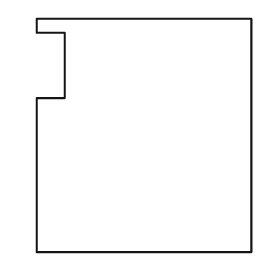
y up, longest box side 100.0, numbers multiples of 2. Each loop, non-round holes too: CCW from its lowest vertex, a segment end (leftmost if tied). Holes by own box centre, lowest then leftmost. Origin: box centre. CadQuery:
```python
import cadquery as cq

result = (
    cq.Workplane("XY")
    .moveTo(-46.0, -50.0)
    .lineTo(46.0, -50.0)
    .lineTo(46.0, 50.0)
    .lineTo(-46.0, 50.0)
    .lineTo(-46.0, 44.0)
    .lineTo(-34.0, 44.0)
    .lineTo(-34.0, 16.0)
    .lineTo(-46.0, 16.0)
    .close()
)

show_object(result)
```